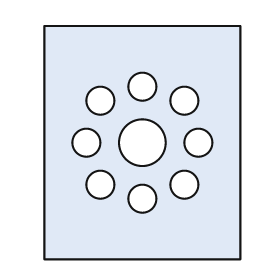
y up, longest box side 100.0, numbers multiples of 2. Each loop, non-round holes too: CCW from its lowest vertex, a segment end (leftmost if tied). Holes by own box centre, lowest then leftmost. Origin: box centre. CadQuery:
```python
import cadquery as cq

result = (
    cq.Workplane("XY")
    .moveTo(-42.0, -50.0)
    .lineTo(42.0, -50.0)
    .lineTo(42.0, 50.0)
    .lineTo(-42.0, 50.0)
    .close()
    .moveTo(0.0, -24.0)
    .circle(6.0)
    .moveTo(-18.0, -18.0)
    .circle(6.0)
    .moveTo(18.0, -18.0)
    .circle(6.0)
    .moveTo(-24.0, 0.0)
    .circle(6.0)
    .moveTo(0.0, 0.0)
    .circle(10.0)
    .moveTo(24.0, 0.0)
    .circle(6.0)
    .moveTo(-18.0, 18.0)
    .circle(6.0)
    .moveTo(18.0, 18.0)
    .circle(6.0)
    .moveTo(0.0, 24.0)
    .circle(6.0)
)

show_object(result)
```